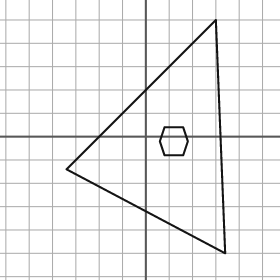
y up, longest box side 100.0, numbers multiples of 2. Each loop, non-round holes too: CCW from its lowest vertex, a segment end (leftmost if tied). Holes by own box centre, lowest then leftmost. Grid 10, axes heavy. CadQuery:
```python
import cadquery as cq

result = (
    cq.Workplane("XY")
    .moveTo(34.0, -50.0)
    .lineTo(30.0, 50.0)
    .lineTo(-34.0, -14.0)
    .close()
    .moveTo(8.0, -8.0)
    .lineTo(16.0, -8.0)
    .lineTo(18.0, -2.0)
    .lineTo(16.0, 4.0)
    .lineTo(8.0, 4.0)
    .lineTo(6.0, -2.0)
    .close()
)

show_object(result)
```